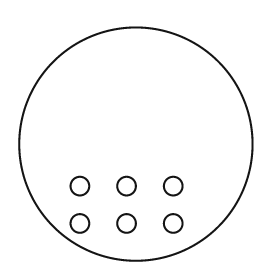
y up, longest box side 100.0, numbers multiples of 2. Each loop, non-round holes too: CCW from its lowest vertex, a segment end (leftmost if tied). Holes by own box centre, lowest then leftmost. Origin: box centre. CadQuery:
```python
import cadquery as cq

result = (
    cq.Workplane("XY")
    .moveTo(0.0, 0.0)
    .circle(50.0)
    .moveTo(-24.0, -34.0)
    .circle(4.0)
    .moveTo(-4.0, -34.0)
    .circle(4.0)
    .moveTo(16.0, -34.0)
    .circle(4.0)
    .moveTo(-24.0, -18.0)
    .circle(4.0)
    .moveTo(-4.0, -18.0)
    .circle(4.0)
    .moveTo(16.0, -18.0)
    .circle(4.0)
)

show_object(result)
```